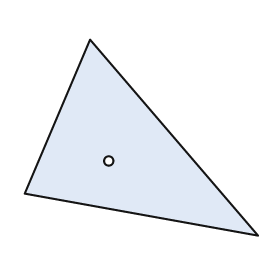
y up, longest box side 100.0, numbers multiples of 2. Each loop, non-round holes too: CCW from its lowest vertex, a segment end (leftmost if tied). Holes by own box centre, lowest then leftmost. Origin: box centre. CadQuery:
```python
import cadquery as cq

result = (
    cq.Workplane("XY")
    .moveTo(50.0, -42.0)
    .lineTo(-22.0, 42.0)
    .lineTo(-50.0, -24.0)
    .close()
    .moveTo(-14.0, -10.0)
    .circle(2.0)
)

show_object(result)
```